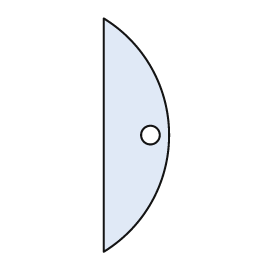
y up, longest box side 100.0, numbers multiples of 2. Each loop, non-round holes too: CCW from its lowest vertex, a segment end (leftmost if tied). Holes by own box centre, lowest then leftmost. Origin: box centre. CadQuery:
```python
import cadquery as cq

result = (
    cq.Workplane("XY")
    .moveTo(-14.0, -50.0)
    .threePointArc((14.0, 0.0), (-14.0, 50.0))
    .close()
    .moveTo(6.0, 0.0)
    .circle(4.0)
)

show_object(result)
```